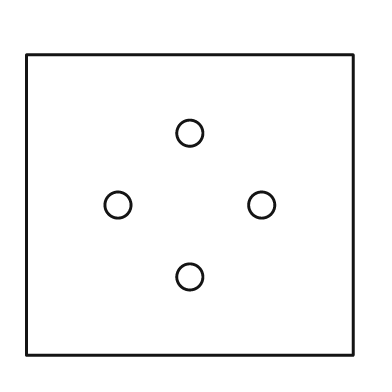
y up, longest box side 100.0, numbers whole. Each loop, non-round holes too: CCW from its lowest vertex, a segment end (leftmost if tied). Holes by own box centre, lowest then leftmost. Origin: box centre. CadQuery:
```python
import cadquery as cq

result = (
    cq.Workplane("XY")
    .moveTo(-50.0, -46.0)
    .lineTo(50.0, -46.0)
    .lineTo(50.0, 46.0)
    .lineTo(-50.0, 46.0)
    .close()
    .moveTo(0.0, -22.0)
    .circle(4.0)
    .moveTo(-22.0, 0.0)
    .circle(4.0)
    .moveTo(22.0, 0.0)
    .circle(4.0)
    .moveTo(0.0, 22.0)
    .circle(4.0)
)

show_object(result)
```